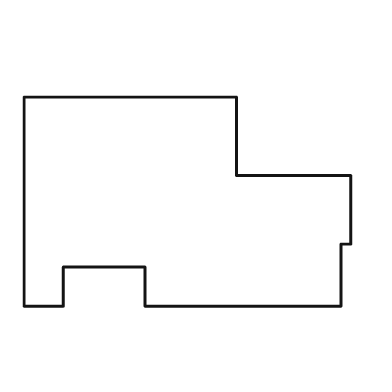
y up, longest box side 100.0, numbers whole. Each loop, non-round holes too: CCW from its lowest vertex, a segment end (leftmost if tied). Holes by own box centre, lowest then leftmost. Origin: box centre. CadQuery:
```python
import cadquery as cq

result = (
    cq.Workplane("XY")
    .moveTo(-50.0, -32.0)
    .lineTo(-38.0, -32.0)
    .lineTo(-38.0, -20.0)
    .lineTo(-13.0, -20.0)
    .lineTo(-13.0, -32.0)
    .lineTo(47.0, -32.0)
    .lineTo(47.0, -13.0)
    .lineTo(50.0, -13.0)
    .lineTo(50.0, 8.0)
    .lineTo(15.0, 8.0)
    .lineTo(15.0, 32.0)
    .lineTo(-50.0, 32.0)
    .close()
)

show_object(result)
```